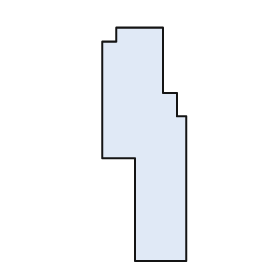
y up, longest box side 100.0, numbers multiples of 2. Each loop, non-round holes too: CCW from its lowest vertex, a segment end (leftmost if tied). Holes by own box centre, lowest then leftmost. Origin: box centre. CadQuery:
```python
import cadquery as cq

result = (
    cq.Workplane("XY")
    .moveTo(-4.0, -50.0)
    .lineTo(18.0, -50.0)
    .lineTo(18.0, 12.0)
    .lineTo(14.0, 12.0)
    .lineTo(14.0, 22.0)
    .lineTo(8.0, 22.0)
    .lineTo(8.0, 50.0)
    .lineTo(-12.0, 50.0)
    .lineTo(-12.0, 44.0)
    .lineTo(-18.0, 44.0)
    .lineTo(-18.0, -6.0)
    .lineTo(-4.0, -6.0)
    .close()
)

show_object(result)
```